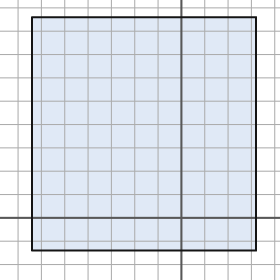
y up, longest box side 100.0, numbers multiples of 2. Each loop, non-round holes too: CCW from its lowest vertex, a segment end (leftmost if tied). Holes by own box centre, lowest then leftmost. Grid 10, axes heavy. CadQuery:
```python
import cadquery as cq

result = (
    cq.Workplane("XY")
    .moveTo(-64.0, -14.0)
    .lineTo(32.0, -14.0)
    .lineTo(32.0, 86.0)
    .lineTo(-64.0, 86.0)
    .close()
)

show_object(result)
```